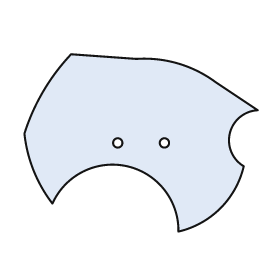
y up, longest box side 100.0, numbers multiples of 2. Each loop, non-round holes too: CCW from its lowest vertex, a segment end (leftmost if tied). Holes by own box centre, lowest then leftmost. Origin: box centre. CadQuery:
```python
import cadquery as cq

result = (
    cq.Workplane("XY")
    .moveTo(16.0, -38.0)
    .threePointArc((34.0, -28.0), (44.0, -10.0))
    .threePointArc((38.0, 4.0), (50.0, 14.0))
    .lineTo(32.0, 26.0)
    .threePointArc((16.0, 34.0), (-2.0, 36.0))
    .lineTo(-30.0, 38.0)
    .threePointArc((-42.0, 22.0), (-50.0, 4.0))
    .threePointArc((-46.0, -12.0), (-38.0, -26.0))
    .threePointArc((-6.0, -10.0), (16.0, -38.0))
    .close()
    .moveTo(-10.0, 0.0)
    .circle(2.0)
    .moveTo(10.0, 0.0)
    .circle(2.0)
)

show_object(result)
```